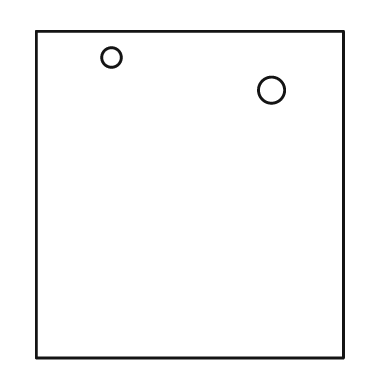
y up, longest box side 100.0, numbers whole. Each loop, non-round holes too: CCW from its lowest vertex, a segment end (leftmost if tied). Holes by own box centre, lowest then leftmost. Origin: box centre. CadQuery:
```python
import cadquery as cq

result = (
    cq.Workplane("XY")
    .moveTo(-47.0, -50.0)
    .lineTo(47.0, -50.0)
    .lineTo(47.0, 50.0)
    .lineTo(-47.0, 50.0)
    .close()
    .moveTo(25.0, 32.0)
    .circle(4.0)
    .moveTo(-24.0, 42.0)
    .circle(3.0)
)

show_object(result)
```